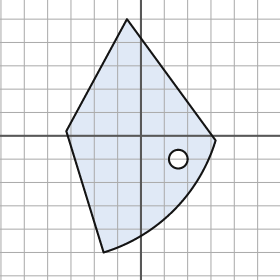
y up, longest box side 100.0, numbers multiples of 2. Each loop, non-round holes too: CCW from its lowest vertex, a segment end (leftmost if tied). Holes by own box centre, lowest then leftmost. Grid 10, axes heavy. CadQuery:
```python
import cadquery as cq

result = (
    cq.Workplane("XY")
    .moveTo(-16.0, -50.0)
    .threePointArc((14.0, -32.0), (32.0, -2.0))
    .lineTo(-6.0, 50.0)
    .lineTo(-32.0, 2.0)
    .close()
    .moveTo(16.0, -10.0)
    .circle(4.0)
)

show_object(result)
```